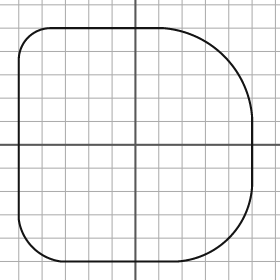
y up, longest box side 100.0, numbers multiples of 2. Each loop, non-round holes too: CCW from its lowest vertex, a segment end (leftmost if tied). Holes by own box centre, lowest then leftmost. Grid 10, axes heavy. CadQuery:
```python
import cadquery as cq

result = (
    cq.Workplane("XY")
    .moveTo(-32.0, -50.0)
    .lineTo(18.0, -50.0)
    .threePointArc((40.0, -40.0), (50.0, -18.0))
    .lineTo(50.0, 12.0)
    .threePointArc((38.0, 38.0), (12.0, 50.0))
    .lineTo(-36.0, 50.0)
    .threePointArc((-46.0, 46.0), (-50.0, 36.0))
    .lineTo(-50.0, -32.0)
    .threePointArc((-44.0, -44.0), (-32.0, -50.0))
    .close()
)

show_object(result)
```